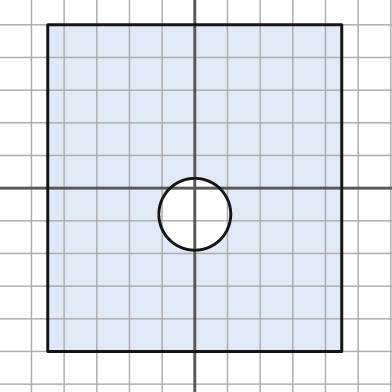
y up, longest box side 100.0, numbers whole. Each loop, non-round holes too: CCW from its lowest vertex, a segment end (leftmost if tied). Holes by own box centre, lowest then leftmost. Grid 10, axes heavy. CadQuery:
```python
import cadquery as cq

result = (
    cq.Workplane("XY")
    .moveTo(-45.0, -50.0)
    .lineTo(45.0, -50.0)
    .lineTo(45.0, 50.0)
    .lineTo(-45.0, 50.0)
    .close()
    .moveTo(0.0, -8.0)
    .circle(11.0)
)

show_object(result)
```